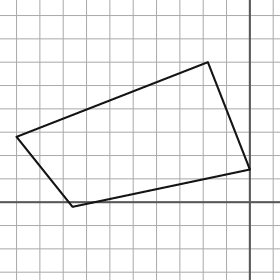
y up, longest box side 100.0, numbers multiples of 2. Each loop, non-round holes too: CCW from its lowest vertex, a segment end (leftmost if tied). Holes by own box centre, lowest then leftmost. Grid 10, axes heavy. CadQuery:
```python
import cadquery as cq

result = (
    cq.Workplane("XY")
    .moveTo(-76.0, -2.0)
    .lineTo(0.0, 14.0)
    .lineTo(-18.0, 60.0)
    .lineTo(-100.0, 28.0)
    .close()
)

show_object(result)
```